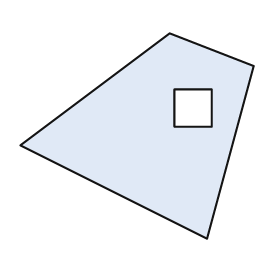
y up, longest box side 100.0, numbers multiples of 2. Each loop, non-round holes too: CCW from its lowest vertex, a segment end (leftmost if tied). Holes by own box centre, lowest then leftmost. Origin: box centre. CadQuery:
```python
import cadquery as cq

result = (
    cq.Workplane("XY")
    .moveTo(30.0, -44.0)
    .lineTo(50.0, 30.0)
    .lineTo(14.0, 44.0)
    .lineTo(-50.0, -4.0)
    .close()
    .moveTo(16.0, 4.0)
    .lineTo(32.0, 4.0)
    .lineTo(32.0, 20.0)
    .lineTo(16.0, 20.0)
    .close()
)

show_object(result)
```